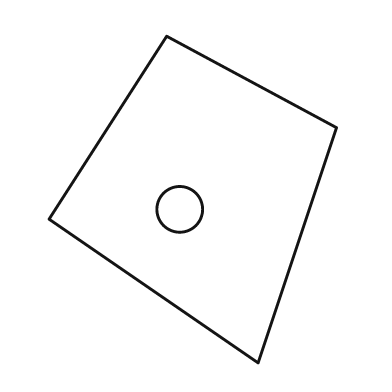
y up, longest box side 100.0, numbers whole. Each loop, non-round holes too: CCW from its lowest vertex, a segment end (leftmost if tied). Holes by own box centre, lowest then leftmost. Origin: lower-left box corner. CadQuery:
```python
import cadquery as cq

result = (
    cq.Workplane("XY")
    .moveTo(64.0, 0.0)
    .lineTo(88.0, 72.0)
    .lineTo(36.0, 100.0)
    .lineTo(0.0, 44.0)
    .close()
    .moveTo(40.0, 47.0)
    .circle(7.0)
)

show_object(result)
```